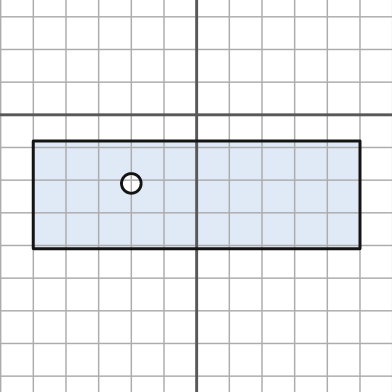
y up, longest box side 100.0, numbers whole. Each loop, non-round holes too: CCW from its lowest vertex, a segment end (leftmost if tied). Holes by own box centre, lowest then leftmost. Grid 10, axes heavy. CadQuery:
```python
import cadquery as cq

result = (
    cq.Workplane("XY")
    .moveTo(-50.0, -41.0)
    .lineTo(50.0, -41.0)
    .lineTo(50.0, -8.0)
    .lineTo(-50.0, -8.0)
    .close()
    .moveTo(-20.0, -21.0)
    .circle(3.0)
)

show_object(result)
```